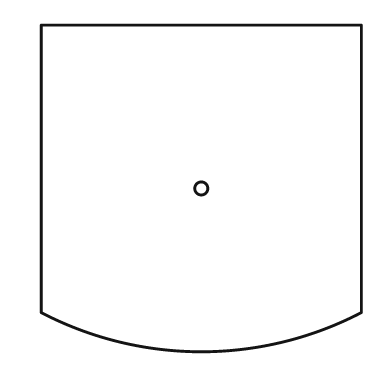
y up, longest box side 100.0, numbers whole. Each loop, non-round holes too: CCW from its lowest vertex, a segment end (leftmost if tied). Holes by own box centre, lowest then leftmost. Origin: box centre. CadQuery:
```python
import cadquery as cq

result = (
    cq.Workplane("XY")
    .moveTo(-49.0, -38.0)
    .threePointArc((0.0, -50.0), (49.0, -38.0))
    .lineTo(49.0, 50.0)
    .lineTo(-49.0, 50.0)
    .close()
    .moveTo(0.0, 0.0)
    .circle(2.0)
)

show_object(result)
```